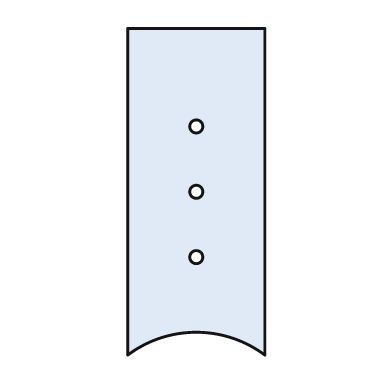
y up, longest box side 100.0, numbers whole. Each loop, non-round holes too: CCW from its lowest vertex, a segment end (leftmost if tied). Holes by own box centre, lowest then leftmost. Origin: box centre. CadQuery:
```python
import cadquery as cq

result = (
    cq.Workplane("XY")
    .moveTo(-21.0, -50.0)
    .threePointArc((0.0, -43.0), (21.0, -50.0))
    .lineTo(21.0, 50.0)
    .lineTo(-21.0, 50.0)
    .close()
    .moveTo(0.0, -20.0)
    .circle(2.0)
    .moveTo(0.0, 0.0)
    .circle(2.0)
    .moveTo(0.0, 20.0)
    .circle(2.0)
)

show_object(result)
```